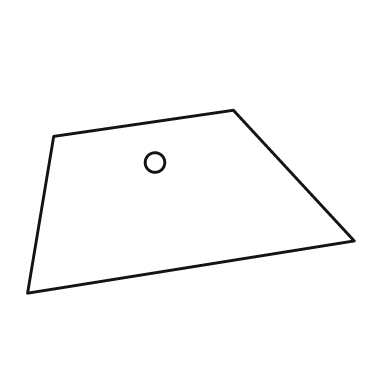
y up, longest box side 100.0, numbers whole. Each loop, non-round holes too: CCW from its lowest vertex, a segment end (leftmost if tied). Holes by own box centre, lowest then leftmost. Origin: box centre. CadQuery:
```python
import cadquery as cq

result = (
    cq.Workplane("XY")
    .moveTo(-50.0, -28.0)
    .lineTo(50.0, -12.0)
    .lineTo(13.0, 28.0)
    .lineTo(-42.0, 20.0)
    .close()
    .moveTo(-11.0, 12.0)
    .circle(3.0)
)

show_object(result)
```